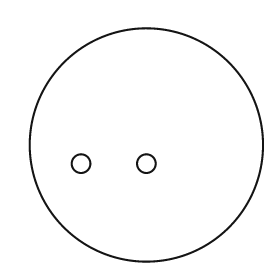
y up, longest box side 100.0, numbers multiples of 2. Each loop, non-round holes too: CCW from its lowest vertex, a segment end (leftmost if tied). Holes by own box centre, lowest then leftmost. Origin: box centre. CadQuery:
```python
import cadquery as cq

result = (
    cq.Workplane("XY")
    .moveTo(0.0, 0.0)
    .circle(50.0)
    .moveTo(-28.0, -8.0)
    .circle(4.0)
    .moveTo(0.0, -8.0)
    .circle(4.0)
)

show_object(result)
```